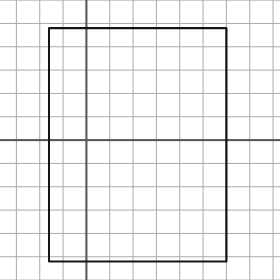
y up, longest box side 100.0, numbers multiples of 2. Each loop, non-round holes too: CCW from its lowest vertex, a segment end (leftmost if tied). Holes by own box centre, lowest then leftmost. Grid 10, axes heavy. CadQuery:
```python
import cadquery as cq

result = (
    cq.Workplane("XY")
    .moveTo(-16.0, -52.0)
    .lineTo(60.0, -52.0)
    .lineTo(60.0, 48.0)
    .lineTo(-16.0, 48.0)
    .close()
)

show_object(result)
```